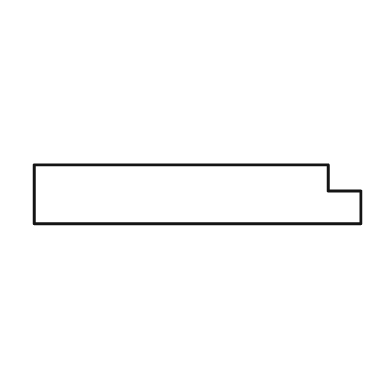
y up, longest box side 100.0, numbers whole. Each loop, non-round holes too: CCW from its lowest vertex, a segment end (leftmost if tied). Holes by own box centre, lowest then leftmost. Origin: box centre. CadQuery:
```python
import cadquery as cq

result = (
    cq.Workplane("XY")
    .moveTo(-50.0, -9.0)
    .lineTo(50.0, -9.0)
    .lineTo(50.0, 1.0)
    .lineTo(40.0, 1.0)
    .lineTo(40.0, 9.0)
    .lineTo(-50.0, 9.0)
    .close()
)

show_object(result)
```